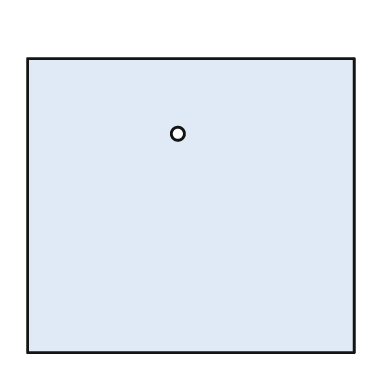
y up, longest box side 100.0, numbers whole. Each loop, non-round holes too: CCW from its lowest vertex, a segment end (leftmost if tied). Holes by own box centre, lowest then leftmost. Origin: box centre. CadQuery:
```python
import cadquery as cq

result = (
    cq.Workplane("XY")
    .moveTo(-50.0, -45.0)
    .lineTo(50.0, -45.0)
    .lineTo(50.0, 45.0)
    .lineTo(-50.0, 45.0)
    .close()
    .moveTo(-4.0, 22.0)
    .circle(2.0)
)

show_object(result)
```